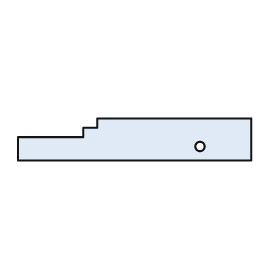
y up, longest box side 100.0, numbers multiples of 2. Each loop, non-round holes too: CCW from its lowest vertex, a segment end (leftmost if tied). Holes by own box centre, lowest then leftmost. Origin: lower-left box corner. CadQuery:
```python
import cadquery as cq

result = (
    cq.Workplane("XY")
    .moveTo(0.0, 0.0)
    .lineTo(100.0, 0.0)
    .lineTo(100.0, 18.0)
    .lineTo(34.0, 18.0)
    .lineTo(34.0, 14.0)
    .lineTo(28.0, 14.0)
    .lineTo(28.0, 10.0)
    .lineTo(0.0, 10.0)
    .close()
    .moveTo(78.0, 6.0)
    .circle(2.0)
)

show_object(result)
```